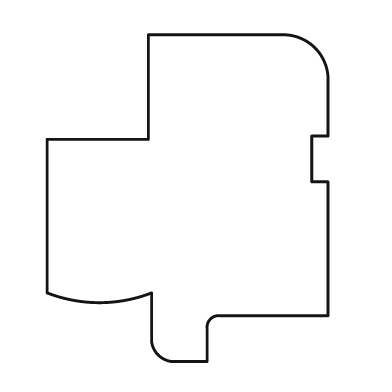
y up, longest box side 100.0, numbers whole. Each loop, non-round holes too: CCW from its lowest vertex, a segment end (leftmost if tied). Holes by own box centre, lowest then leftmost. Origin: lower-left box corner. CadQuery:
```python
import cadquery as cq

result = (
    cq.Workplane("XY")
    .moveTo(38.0, 0.0)
    .lineTo(49.0, 0.0)
    .lineTo(49.0, 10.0)
    .threePointArc((50.0, 13.0), (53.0, 14.0))
    .lineTo(86.0, 14.0)
    .lineTo(86.0, 55.0)
    .lineTo(81.0, 55.0)
    .lineTo(81.0, 69.0)
    .lineTo(86.0, 69.0)
    .lineTo(86.0, 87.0)
    .threePointArc((82.0, 96.0), (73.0, 100.0))
    .lineTo(31.0, 100.0)
    .lineTo(31.0, 68.0)
    .lineTo(0.0, 68.0)
    .lineTo(0.0, 21.0)
    .threePointArc((16.0, 18.0), (32.0, 21.0))
    .lineTo(32.0, 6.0)
    .threePointArc((34.0, 2.0), (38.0, 0.0))
    .close()
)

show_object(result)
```